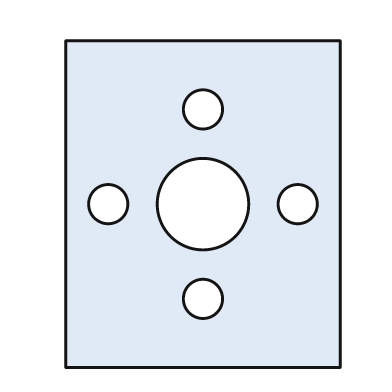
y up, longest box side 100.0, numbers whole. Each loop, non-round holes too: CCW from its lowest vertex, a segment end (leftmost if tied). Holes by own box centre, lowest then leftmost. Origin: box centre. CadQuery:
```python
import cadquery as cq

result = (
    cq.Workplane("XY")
    .moveTo(-42.0, -50.0)
    .lineTo(42.0, -50.0)
    .lineTo(42.0, 50.0)
    .lineTo(-42.0, 50.0)
    .close()
    .moveTo(0.0, -29.0)
    .circle(6.0)
    .moveTo(-29.0, 0.0)
    .circle(6.0)
    .moveTo(0.0, 0.0)
    .circle(14.0)
    .moveTo(29.0, 0.0)
    .circle(6.0)
    .moveTo(0.0, 29.0)
    .circle(6.0)
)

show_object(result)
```